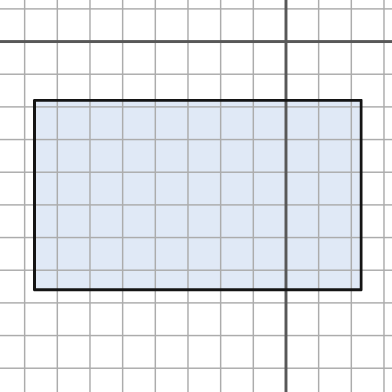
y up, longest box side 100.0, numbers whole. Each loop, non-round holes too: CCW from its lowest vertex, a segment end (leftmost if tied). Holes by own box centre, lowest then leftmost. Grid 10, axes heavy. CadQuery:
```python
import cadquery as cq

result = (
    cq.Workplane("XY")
    .moveTo(-77.0, -76.0)
    .lineTo(23.0, -76.0)
    .lineTo(23.0, -18.0)
    .lineTo(-77.0, -18.0)
    .close()
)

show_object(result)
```